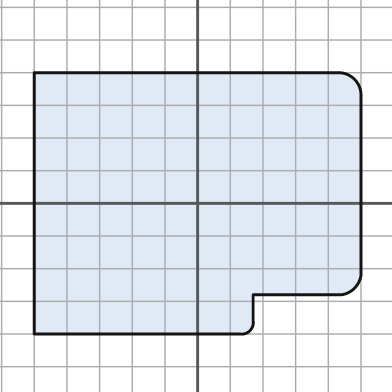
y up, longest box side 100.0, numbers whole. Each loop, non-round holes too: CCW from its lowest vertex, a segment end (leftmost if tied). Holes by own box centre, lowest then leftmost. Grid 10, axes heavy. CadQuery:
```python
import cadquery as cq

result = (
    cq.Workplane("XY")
    .moveTo(-50.0, -40.0)
    .lineTo(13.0, -40.0)
    .threePointArc((16.0, -39.0), (17.0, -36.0))
    .lineTo(17.0, -28.0)
    .lineTo(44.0, -28.0)
    .threePointArc((48.0, -26.0), (50.0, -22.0))
    .lineTo(50.0, 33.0)
    .threePointArc((48.0, 38.0), (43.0, 40.0))
    .lineTo(-50.0, 40.0)
    .close()
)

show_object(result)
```